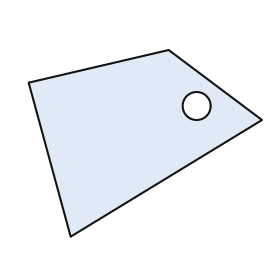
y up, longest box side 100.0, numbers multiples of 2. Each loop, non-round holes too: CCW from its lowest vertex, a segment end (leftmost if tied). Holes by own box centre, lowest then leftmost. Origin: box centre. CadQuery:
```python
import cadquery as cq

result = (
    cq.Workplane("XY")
    .moveTo(-32.0, -40.0)
    .lineTo(50.0, 10.0)
    .lineTo(10.0, 40.0)
    .lineTo(-50.0, 26.0)
    .close()
    .moveTo(22.0, 16.0)
    .circle(6.0)
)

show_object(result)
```